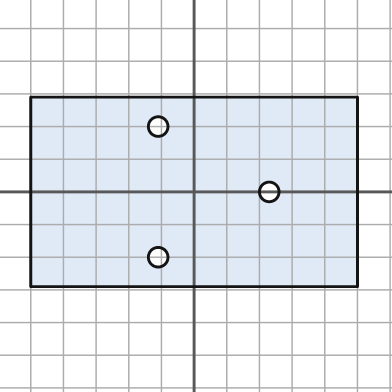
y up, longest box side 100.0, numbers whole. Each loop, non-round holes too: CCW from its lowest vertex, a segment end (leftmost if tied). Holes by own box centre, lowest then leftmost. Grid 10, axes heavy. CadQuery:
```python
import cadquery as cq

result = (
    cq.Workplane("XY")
    .moveTo(-50.0, -29.0)
    .lineTo(50.0, -29.0)
    .lineTo(50.0, 29.0)
    .lineTo(-50.0, 29.0)
    .close()
    .moveTo(-11.0, -20.0)
    .circle(3.0)
    .moveTo(23.0, 0.0)
    .circle(3.0)
    .moveTo(-11.0, 20.0)
    .circle(3.0)
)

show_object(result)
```